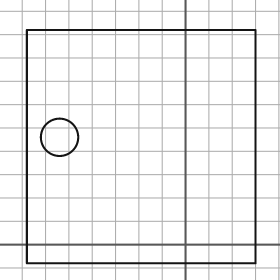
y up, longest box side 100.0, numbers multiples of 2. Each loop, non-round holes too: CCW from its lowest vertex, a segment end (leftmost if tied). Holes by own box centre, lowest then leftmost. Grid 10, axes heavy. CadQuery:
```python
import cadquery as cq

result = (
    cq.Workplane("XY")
    .moveTo(-68.0, -8.0)
    .lineTo(30.0, -8.0)
    .lineTo(30.0, 92.0)
    .lineTo(-68.0, 92.0)
    .close()
    .moveTo(-54.0, 46.0)
    .circle(8.0)
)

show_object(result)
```